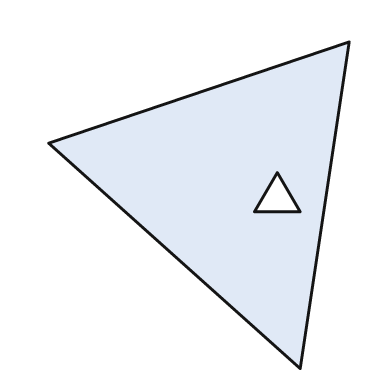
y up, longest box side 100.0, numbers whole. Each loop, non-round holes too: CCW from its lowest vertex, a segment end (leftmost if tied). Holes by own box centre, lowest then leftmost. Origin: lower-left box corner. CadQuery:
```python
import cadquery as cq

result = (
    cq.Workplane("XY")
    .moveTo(77.0, 0.0)
    .lineTo(92.0, 100.0)
    .lineTo(0.0, 69.0)
    .close()
    .moveTo(63.0, 48.0)
    .lineTo(77.0, 48.0)
    .lineTo(70.0, 60.0)
    .close()
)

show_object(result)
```